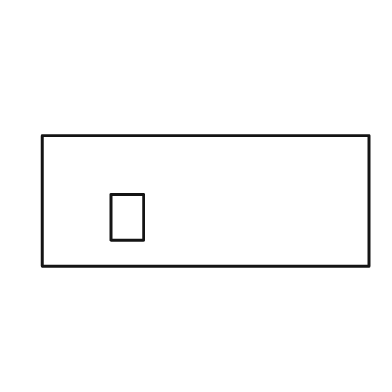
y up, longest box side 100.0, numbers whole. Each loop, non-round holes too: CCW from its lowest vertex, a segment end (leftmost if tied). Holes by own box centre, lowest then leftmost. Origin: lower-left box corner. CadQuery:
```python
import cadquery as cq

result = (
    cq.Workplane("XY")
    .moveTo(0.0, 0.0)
    .lineTo(100.0, 0.0)
    .lineTo(100.0, 40.0)
    .lineTo(0.0, 40.0)
    .close()
    .moveTo(21.0, 8.0)
    .lineTo(31.0, 8.0)
    .lineTo(31.0, 22.0)
    .lineTo(21.0, 22.0)
    .close()
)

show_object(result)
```